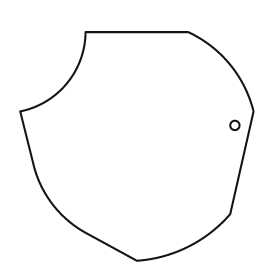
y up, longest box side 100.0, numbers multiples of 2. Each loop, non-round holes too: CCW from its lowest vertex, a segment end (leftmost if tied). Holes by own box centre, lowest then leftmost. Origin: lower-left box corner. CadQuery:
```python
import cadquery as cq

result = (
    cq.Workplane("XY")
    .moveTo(50.0, 0.0)
    .threePointArc((72.0, 6.0), (90.0, 20.0))
    .lineTo(100.0, 64.0)
    .threePointArc((90.0, 84.0), (72.0, 98.0))
    .lineTo(28.0, 98.0)
    .threePointArc((20.0, 76.0), (0.0, 64.0))
    .lineTo(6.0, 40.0)
    .threePointArc((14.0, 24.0), (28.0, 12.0))
    .close()
    .moveTo(92.0, 58.0)
    .circle(2.0)
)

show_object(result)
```